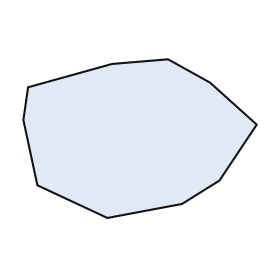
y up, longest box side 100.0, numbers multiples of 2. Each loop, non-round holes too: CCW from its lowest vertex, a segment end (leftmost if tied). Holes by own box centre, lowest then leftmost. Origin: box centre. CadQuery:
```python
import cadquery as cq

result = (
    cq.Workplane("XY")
    .moveTo(-14.0, -34.0)
    .lineTo(18.0, -28.0)
    .lineTo(34.0, -18.0)
    .lineTo(50.0, 6.0)
    .lineTo(30.0, 24.0)
    .lineTo(12.0, 34.0)
    .lineTo(-12.0, 32.0)
    .lineTo(-48.0, 22.0)
    .lineTo(-50.0, 8.0)
    .lineTo(-44.0, -20.0)
    .close()
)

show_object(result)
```